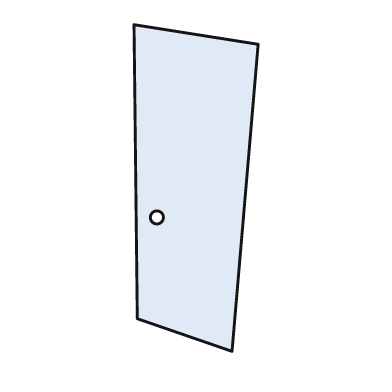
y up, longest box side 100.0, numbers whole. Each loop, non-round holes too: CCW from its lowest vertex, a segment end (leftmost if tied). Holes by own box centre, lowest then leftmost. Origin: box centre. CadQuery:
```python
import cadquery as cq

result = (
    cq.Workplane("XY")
    .moveTo(11.0, -50.0)
    .lineTo(19.0, 44.0)
    .lineTo(-19.0, 50.0)
    .lineTo(-18.0, -40.0)
    .close()
    .moveTo(-12.0, -9.0)
    .circle(2.0)
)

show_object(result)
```